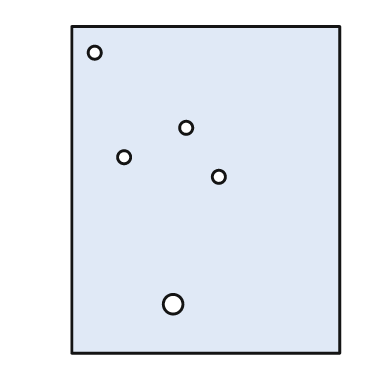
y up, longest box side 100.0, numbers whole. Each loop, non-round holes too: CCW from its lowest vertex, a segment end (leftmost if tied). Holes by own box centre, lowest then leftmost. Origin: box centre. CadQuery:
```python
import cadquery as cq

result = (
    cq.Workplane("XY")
    .moveTo(-41.0, -50.0)
    .lineTo(41.0, -50.0)
    .lineTo(41.0, 50.0)
    .lineTo(-41.0, 50.0)
    .close()
    .moveTo(-10.0, -35.0)
    .circle(3.0)
    .moveTo(4.0, 4.0)
    .circle(2.0)
    .moveTo(-25.0, 10.0)
    .circle(2.0)
    .moveTo(-6.0, 19.0)
    .circle(2.0)
    .moveTo(-34.0, 42.0)
    .circle(2.0)
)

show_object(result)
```